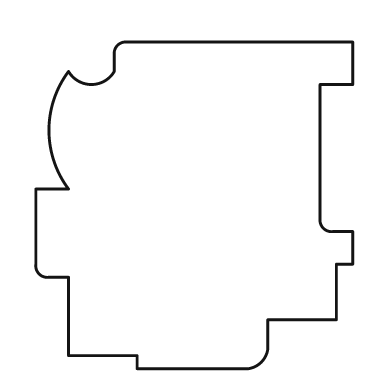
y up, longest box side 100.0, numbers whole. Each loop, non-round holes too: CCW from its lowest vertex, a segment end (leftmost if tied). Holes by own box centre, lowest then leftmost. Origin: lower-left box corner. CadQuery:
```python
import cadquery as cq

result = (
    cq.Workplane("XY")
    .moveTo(31.0, 0.0)
    .lineTo(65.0, 0.0)
    .threePointArc((69.0, 2.0), (71.0, 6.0))
    .lineTo(71.0, 15.0)
    .lineTo(92.0, 15.0)
    .lineTo(92.0, 32.0)
    .lineTo(97.0, 32.0)
    .lineTo(97.0, 42.0)
    .lineTo(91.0, 42.0)
    .threePointArc((88.0, 43.0), (87.0, 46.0))
    .lineTo(87.0, 87.0)
    .lineTo(97.0, 87.0)
    .lineTo(97.0, 100.0)
    .lineTo(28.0, 100.0)
    .threePointArc((25.0, 99.0), (24.0, 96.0))
    .lineTo(24.0, 91.0)
    .threePointArc((17.0, 87.0), (10.0, 91.0))
    .threePointArc((4.0, 73.0), (10.0, 55.0))
    .lineTo(0.0, 55.0)
    .lineTo(0.0, 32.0)
    .threePointArc((1.0, 29.0), (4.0, 28.0))
    .lineTo(10.0, 28.0)
    .lineTo(10.0, 4.0)
    .lineTo(31.0, 4.0)
    .close()
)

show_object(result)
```